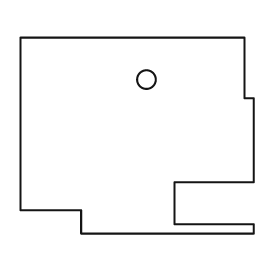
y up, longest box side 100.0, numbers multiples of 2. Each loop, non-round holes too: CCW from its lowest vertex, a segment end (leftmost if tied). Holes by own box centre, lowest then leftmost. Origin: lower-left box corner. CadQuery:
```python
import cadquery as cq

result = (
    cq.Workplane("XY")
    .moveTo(26.0, 0.0)
    .lineTo(100.0, 0.0)
    .lineTo(100.0, 4.0)
    .lineTo(66.0, 4.0)
    .lineTo(66.0, 22.0)
    .lineTo(100.0, 22.0)
    .lineTo(100.0, 58.0)
    .lineTo(96.0, 58.0)
    .lineTo(96.0, 84.0)
    .lineTo(0.0, 84.0)
    .lineTo(0.0, 10.0)
    .lineTo(26.0, 10.0)
    .close()
    .moveTo(54.0, 66.0)
    .circle(4.0)
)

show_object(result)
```